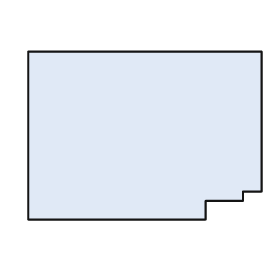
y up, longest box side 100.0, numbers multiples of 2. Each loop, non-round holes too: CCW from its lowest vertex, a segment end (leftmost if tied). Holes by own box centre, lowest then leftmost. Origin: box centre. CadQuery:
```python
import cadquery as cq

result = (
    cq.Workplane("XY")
    .moveTo(-50.0, -36.0)
    .lineTo(26.0, -36.0)
    .lineTo(26.0, -28.0)
    .lineTo(42.0, -28.0)
    .lineTo(42.0, -24.0)
    .lineTo(50.0, -24.0)
    .lineTo(50.0, 36.0)
    .lineTo(-50.0, 36.0)
    .close()
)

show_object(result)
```